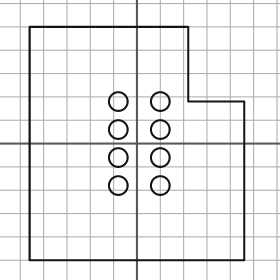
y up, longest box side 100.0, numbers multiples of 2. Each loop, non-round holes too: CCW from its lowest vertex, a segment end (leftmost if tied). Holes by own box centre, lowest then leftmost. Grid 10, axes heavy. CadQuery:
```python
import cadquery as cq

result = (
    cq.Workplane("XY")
    .moveTo(-46.0, -50.0)
    .lineTo(46.0, -50.0)
    .lineTo(46.0, 18.0)
    .lineTo(22.0, 18.0)
    .lineTo(22.0, 50.0)
    .lineTo(-46.0, 50.0)
    .close()
    .moveTo(-8.0, -18.0)
    .circle(4.0)
    .moveTo(10.0, -18.0)
    .circle(4.0)
    .moveTo(-8.0, -6.0)
    .circle(4.0)
    .moveTo(10.0, -6.0)
    .circle(4.0)
    .moveTo(-8.0, 6.0)
    .circle(4.0)
    .moveTo(10.0, 6.0)
    .circle(4.0)
    .moveTo(-8.0, 18.0)
    .circle(4.0)
    .moveTo(10.0, 18.0)
    .circle(4.0)
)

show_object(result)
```